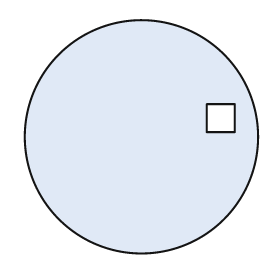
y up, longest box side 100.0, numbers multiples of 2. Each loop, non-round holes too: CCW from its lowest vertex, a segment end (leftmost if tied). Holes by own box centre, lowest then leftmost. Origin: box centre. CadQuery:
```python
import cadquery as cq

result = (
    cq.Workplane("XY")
    .moveTo(0.0, 0.0)
    .circle(50.0)
    .moveTo(28.0, 2.0)
    .lineTo(40.0, 2.0)
    .lineTo(40.0, 14.0)
    .lineTo(28.0, 14.0)
    .close()
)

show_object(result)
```